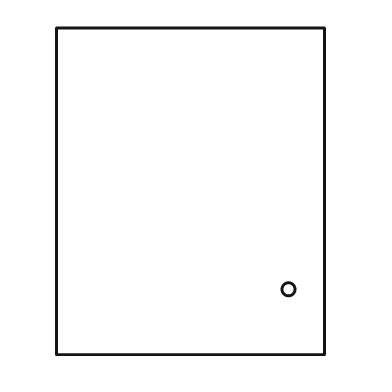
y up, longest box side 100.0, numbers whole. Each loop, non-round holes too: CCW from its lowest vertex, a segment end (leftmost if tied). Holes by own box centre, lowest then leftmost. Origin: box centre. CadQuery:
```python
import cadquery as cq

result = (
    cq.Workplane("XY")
    .moveTo(-41.0, -50.0)
    .lineTo(41.0, -50.0)
    .lineTo(41.0, 50.0)
    .lineTo(-41.0, 50.0)
    .close()
    .moveTo(30.0, -30.0)
    .circle(2.0)
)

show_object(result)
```